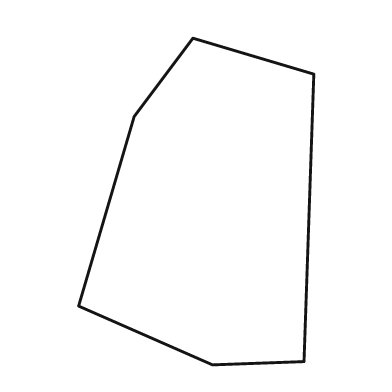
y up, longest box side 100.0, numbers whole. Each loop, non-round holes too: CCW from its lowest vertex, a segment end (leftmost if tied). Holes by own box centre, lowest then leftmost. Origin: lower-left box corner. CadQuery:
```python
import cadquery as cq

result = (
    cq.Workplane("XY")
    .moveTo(41.0, 0.0)
    .lineTo(69.0, 1.0)
    .lineTo(72.0, 89.0)
    .lineTo(35.0, 100.0)
    .lineTo(17.0, 76.0)
    .lineTo(0.0, 18.0)
    .close()
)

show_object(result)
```